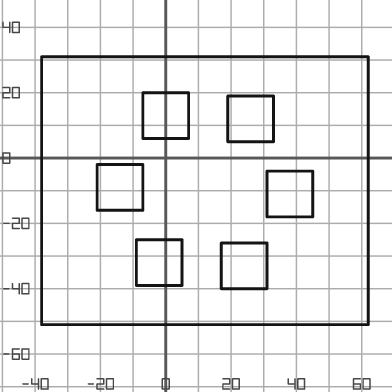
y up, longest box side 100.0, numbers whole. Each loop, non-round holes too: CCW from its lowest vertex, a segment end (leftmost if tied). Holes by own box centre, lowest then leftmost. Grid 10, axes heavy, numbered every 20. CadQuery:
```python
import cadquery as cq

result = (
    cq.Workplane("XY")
    .moveTo(-38.0, -51.0)
    .lineTo(62.0, -51.0)
    .lineTo(62.0, 31.0)
    .lineTo(-38.0, 31.0)
    .close()
    .moveTo(17.0, -40.0)
    .lineTo(31.0, -40.0)
    .lineTo(31.0, -26.0)
    .lineTo(17.0, -26.0)
    .close()
    .moveTo(-9.0, -39.0)
    .lineTo(5.0, -39.0)
    .lineTo(5.0, -25.0)
    .lineTo(-9.0, -25.0)
    .close()
    .moveTo(31.0, -18.0)
    .lineTo(45.0, -18.0)
    .lineTo(45.0, -4.0)
    .lineTo(31.0, -4.0)
    .close()
    .moveTo(-21.0, -16.0)
    .lineTo(-7.0, -16.0)
    .lineTo(-7.0, -2.0)
    .lineTo(-21.0, -2.0)
    .close()
    .moveTo(19.0, 5.0)
    .lineTo(33.0, 5.0)
    .lineTo(33.0, 19.0)
    .lineTo(19.0, 19.0)
    .close()
    .moveTo(-7.0, 6.0)
    .lineTo(7.0, 6.0)
    .lineTo(7.0, 20.0)
    .lineTo(-7.0, 20.0)
    .close()
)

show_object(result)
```